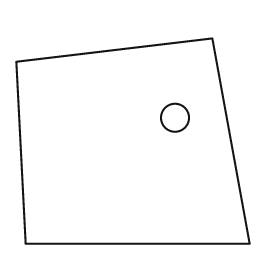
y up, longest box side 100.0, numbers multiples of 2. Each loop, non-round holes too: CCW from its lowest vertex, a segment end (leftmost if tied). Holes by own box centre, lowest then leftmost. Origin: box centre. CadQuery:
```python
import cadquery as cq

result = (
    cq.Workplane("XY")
    .moveTo(-46.0, -44.0)
    .lineTo(50.0, -44.0)
    .lineTo(34.0, 44.0)
    .lineTo(-50.0, 34.0)
    .close()
    .moveTo(18.0, 10.0)
    .circle(6.0)
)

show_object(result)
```